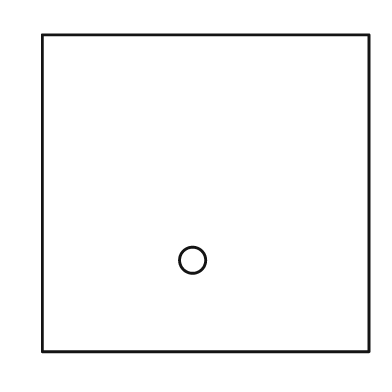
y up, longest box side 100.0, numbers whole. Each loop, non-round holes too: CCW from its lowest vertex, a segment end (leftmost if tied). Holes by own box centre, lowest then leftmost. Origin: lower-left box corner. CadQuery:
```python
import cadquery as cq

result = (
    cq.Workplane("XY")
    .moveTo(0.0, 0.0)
    .lineTo(100.0, 0.0)
    .lineTo(100.0, 97.0)
    .lineTo(0.0, 97.0)
    .close()
    .moveTo(46.0, 28.0)
    .circle(4.0)
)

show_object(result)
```